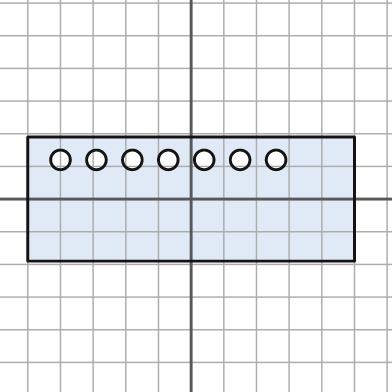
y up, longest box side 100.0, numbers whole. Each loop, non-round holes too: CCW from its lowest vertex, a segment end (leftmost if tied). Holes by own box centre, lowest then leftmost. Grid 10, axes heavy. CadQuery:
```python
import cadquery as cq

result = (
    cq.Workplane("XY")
    .moveTo(-50.0, -19.0)
    .lineTo(50.0, -19.0)
    .lineTo(50.0, 19.0)
    .lineTo(-50.0, 19.0)
    .close()
    .moveTo(-40.0, 12.0)
    .circle(3.0)
    .moveTo(-29.0, 12.0)
    .circle(3.0)
    .moveTo(-18.0, 12.0)
    .circle(3.0)
    .moveTo(-7.0, 12.0)
    .circle(3.0)
    .moveTo(4.0, 12.0)
    .circle(3.0)
    .moveTo(15.0, 12.0)
    .circle(3.0)
    .moveTo(26.0, 12.0)
    .circle(3.0)
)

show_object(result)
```